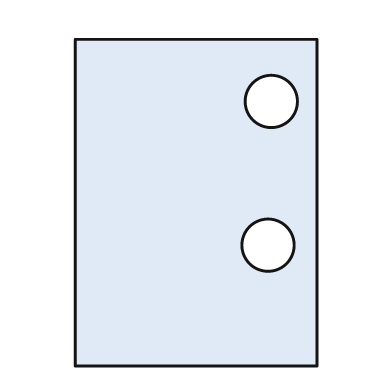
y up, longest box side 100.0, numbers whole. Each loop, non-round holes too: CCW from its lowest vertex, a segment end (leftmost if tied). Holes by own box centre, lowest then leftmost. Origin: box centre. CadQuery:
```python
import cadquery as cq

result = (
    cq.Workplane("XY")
    .moveTo(-37.0, -50.0)
    .lineTo(37.0, -50.0)
    .lineTo(37.0, 50.0)
    .lineTo(-37.0, 50.0)
    .close()
    .moveTo(22.0, -13.0)
    .circle(8.0)
    .moveTo(23.0, 31.0)
    .circle(8.0)
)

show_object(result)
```